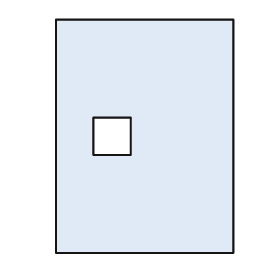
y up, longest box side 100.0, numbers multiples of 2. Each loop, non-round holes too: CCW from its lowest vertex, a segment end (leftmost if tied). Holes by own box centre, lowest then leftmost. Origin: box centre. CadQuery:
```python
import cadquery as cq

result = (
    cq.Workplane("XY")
    .moveTo(-38.0, -50.0)
    .lineTo(38.0, -50.0)
    .lineTo(38.0, 50.0)
    .lineTo(-38.0, 50.0)
    .close()
    .moveTo(-22.0, -8.0)
    .lineTo(-6.0, -8.0)
    .lineTo(-6.0, 8.0)
    .lineTo(-22.0, 8.0)
    .close()
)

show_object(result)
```